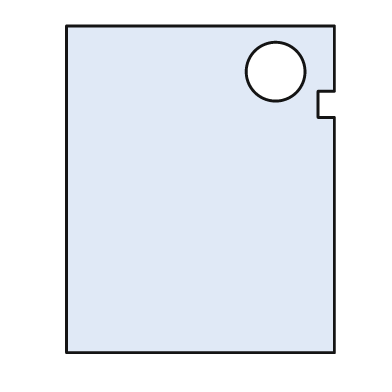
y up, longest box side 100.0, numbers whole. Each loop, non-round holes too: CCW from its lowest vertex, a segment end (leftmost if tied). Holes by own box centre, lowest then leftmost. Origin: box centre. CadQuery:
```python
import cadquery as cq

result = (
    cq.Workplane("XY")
    .moveTo(-41.0, -50.0)
    .lineTo(41.0, -50.0)
    .lineTo(41.0, 22.0)
    .lineTo(36.0, 22.0)
    .lineTo(36.0, 30.0)
    .lineTo(41.0, 30.0)
    .lineTo(41.0, 50.0)
    .lineTo(-41.0, 50.0)
    .close()
    .moveTo(23.0, 36.0)
    .circle(9.0)
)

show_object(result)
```